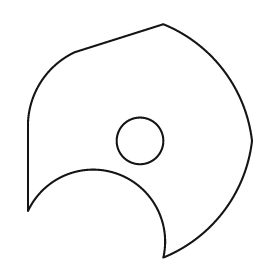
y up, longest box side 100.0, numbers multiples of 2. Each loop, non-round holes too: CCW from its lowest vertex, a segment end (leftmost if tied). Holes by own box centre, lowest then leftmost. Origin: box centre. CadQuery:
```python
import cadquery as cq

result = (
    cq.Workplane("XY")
    .moveTo(10.0, -50.0)
    .threePointArc((36.0, -30.0), (48.0, 0.0))
    .threePointArc((36.0, 30.0), (10.0, 50.0))
    .lineTo(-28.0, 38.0)
    .threePointArc((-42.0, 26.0), (-48.0, 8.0))
    .lineTo(-48.0, -30.0)
    .threePointArc((-10.0, -14.0), (10.0, -50.0))
    .close()
    .moveTo(0.0, 0.0)
    .circle(10.0)
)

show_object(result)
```